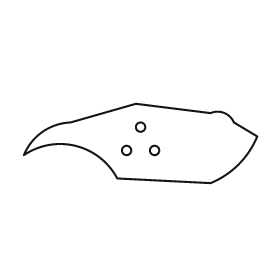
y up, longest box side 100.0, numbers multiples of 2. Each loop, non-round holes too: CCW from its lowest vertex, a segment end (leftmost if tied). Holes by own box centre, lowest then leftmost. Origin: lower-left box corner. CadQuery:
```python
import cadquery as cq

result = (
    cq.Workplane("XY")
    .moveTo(80.0, 0.0)
    .threePointArc((92.0, 8.0), (100.0, 20.0))
    .lineTo(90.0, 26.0)
    .threePointArc((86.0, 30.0), (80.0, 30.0))
    .lineTo(48.0, 34.0)
    .lineTo(20.0, 26.0)
    .threePointArc((8.0, 22.0), (0.0, 12.0))
    .threePointArc((22.0, 16.0), (40.0, 2.0))
    .close()
    .moveTo(44.0, 14.0)
    .circle(2.0)
    .moveTo(56.0, 14.0)
    .circle(2.0)
    .moveTo(50.0, 24.0)
    .circle(2.0)
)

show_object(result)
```